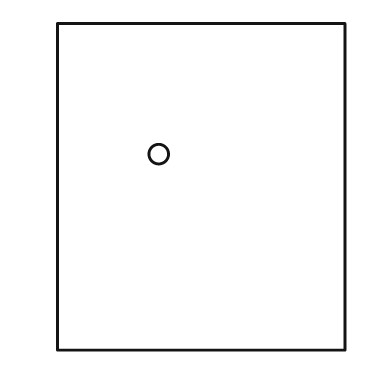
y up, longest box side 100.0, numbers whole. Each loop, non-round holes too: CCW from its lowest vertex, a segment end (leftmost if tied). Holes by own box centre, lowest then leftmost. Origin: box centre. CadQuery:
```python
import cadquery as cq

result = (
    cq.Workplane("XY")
    .moveTo(-44.0, -50.0)
    .lineTo(44.0, -50.0)
    .lineTo(44.0, 50.0)
    .lineTo(-44.0, 50.0)
    .close()
    .moveTo(-13.0, 10.0)
    .circle(3.0)
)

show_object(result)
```